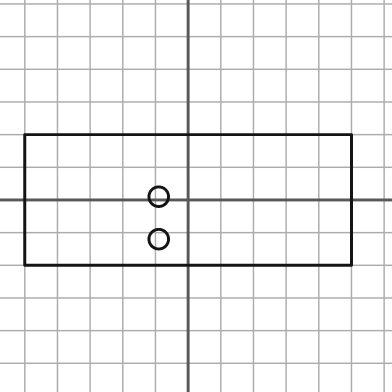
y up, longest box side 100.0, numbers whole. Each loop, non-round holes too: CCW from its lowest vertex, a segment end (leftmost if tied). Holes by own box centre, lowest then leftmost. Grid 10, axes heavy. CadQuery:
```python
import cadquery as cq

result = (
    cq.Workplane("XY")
    .moveTo(-50.0, -20.0)
    .lineTo(50.0, -20.0)
    .lineTo(50.0, 20.0)
    .lineTo(-50.0, 20.0)
    .close()
    .moveTo(-9.0, -12.0)
    .circle(3.0)
    .moveTo(-9.0, 1.0)
    .circle(3.0)
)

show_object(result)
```